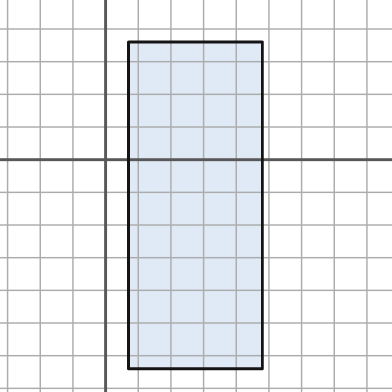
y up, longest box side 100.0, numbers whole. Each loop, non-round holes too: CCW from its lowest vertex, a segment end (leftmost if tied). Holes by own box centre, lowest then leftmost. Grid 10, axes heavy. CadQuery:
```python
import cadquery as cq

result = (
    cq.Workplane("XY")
    .moveTo(7.0, -64.0)
    .lineTo(48.0, -64.0)
    .lineTo(48.0, 36.0)
    .lineTo(7.0, 36.0)
    .close()
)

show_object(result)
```